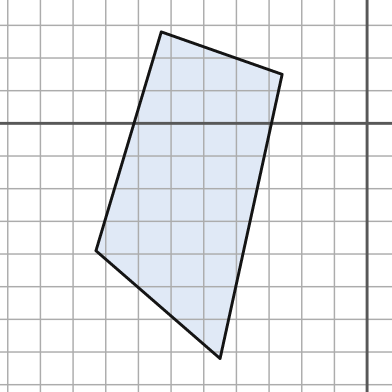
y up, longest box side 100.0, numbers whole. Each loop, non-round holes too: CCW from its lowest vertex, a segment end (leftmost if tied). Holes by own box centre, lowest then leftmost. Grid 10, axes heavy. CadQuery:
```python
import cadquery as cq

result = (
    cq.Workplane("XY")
    .moveTo(-45.0, -72.0)
    .lineTo(-26.0, 15.0)
    .lineTo(-63.0, 28.0)
    .lineTo(-83.0, -39.0)
    .close()
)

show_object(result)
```